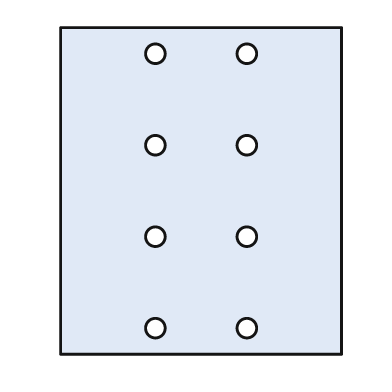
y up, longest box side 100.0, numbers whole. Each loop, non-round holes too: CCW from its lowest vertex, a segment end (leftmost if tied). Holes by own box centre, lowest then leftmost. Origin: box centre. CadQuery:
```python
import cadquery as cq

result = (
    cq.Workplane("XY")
    .moveTo(-43.0, -50.0)
    .lineTo(43.0, -50.0)
    .lineTo(43.0, 50.0)
    .lineTo(-43.0, 50.0)
    .close()
    .moveTo(-14.0, -42.0)
    .circle(3.0)
    .moveTo(14.0, -42.0)
    .circle(3.0)
    .moveTo(-14.0, -14.0)
    .circle(3.0)
    .moveTo(14.0, -14.0)
    .circle(3.0)
    .moveTo(-14.0, 14.0)
    .circle(3.0)
    .moveTo(14.0, 14.0)
    .circle(3.0)
    .moveTo(-14.0, 42.0)
    .circle(3.0)
    .moveTo(14.0, 42.0)
    .circle(3.0)
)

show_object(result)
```